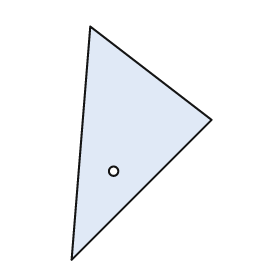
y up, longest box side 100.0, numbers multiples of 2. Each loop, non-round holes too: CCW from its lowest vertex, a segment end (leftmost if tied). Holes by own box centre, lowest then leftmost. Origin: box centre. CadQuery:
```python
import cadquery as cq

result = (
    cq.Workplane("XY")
    .moveTo(-30.0, -50.0)
    .lineTo(30.0, 10.0)
    .lineTo(-22.0, 50.0)
    .close()
    .moveTo(-12.0, -12.0)
    .circle(2.0)
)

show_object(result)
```